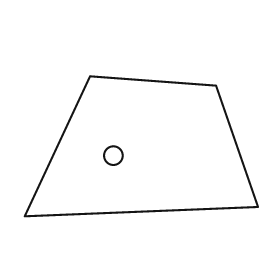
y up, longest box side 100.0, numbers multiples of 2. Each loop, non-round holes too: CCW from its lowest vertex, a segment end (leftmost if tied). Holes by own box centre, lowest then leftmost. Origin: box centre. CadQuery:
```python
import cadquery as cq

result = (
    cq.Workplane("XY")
    .moveTo(-50.0, -30.0)
    .lineTo(50.0, -26.0)
    .lineTo(32.0, 26.0)
    .lineTo(-22.0, 30.0)
    .close()
    .moveTo(-12.0, -4.0)
    .circle(4.0)
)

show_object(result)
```